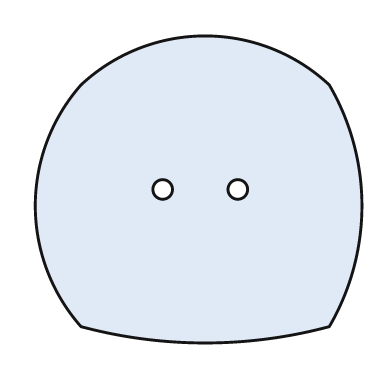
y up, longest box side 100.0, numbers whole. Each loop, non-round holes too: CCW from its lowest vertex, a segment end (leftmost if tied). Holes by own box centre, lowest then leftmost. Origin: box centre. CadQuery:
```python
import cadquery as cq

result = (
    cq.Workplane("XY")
    .moveTo(-36.0, -42.0)
    .threePointArc((2.0, -47.0), (40.0, -42.0))
    .threePointArc((50.0, -5.0), (40.0, 32.0))
    .threePointArc((2.0, 47.0), (-36.0, 32.0))
    .threePointArc((-50.0, -5.0), (-36.0, -42.0))
    .close()
    .moveTo(-11.0, 0.0)
    .circle(3.0)
    .moveTo(12.0, 0.0)
    .circle(3.0)
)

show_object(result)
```